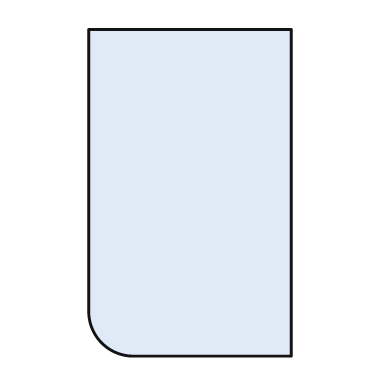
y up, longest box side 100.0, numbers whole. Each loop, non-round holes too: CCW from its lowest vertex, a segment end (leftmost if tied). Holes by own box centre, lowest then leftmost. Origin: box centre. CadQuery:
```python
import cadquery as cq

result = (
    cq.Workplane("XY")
    .moveTo(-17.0, -50.0)
    .lineTo(31.0, -50.0)
    .lineTo(31.0, 50.0)
    .lineTo(-31.0, 50.0)
    .lineTo(-31.0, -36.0)
    .threePointArc((-27.0, -46.0), (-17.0, -50.0))
    .close()
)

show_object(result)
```